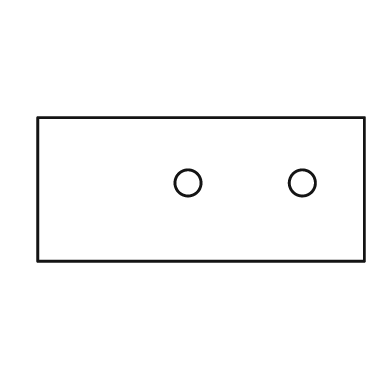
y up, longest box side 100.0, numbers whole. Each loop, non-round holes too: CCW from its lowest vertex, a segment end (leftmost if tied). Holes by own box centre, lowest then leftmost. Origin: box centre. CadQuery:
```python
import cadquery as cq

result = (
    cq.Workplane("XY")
    .moveTo(-50.0, -22.0)
    .lineTo(50.0, -22.0)
    .lineTo(50.0, 22.0)
    .lineTo(-50.0, 22.0)
    .close()
    .moveTo(-4.0, 2.0)
    .circle(4.0)
    .moveTo(31.0, 2.0)
    .circle(4.0)
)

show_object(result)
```